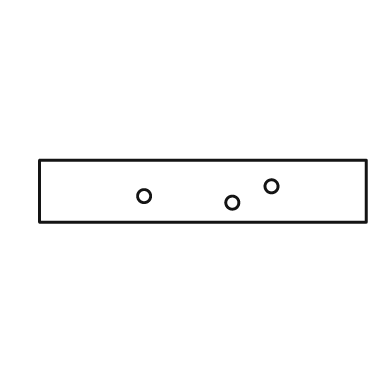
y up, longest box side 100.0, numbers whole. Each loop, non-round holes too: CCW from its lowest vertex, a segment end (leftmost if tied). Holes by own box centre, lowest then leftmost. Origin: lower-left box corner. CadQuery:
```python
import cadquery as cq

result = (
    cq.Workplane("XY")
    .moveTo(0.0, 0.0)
    .lineTo(100.0, 0.0)
    .lineTo(100.0, 19.0)
    .lineTo(0.0, 19.0)
    .close()
    .moveTo(59.0, 6.0)
    .circle(2.0)
    .moveTo(32.0, 8.0)
    .circle(2.0)
    .moveTo(71.0, 11.0)
    .circle(2.0)
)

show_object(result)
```